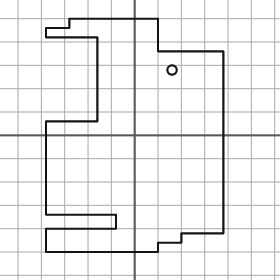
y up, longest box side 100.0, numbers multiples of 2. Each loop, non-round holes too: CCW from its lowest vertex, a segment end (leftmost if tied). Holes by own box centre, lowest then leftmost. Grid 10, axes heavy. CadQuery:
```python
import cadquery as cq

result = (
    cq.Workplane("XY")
    .moveTo(-38.0, -50.0)
    .lineTo(10.0, -50.0)
    .lineTo(10.0, -46.0)
    .lineTo(20.0, -46.0)
    .lineTo(20.0, -42.0)
    .lineTo(38.0, -42.0)
    .lineTo(38.0, 36.0)
    .lineTo(10.0, 36.0)
    .lineTo(10.0, 50.0)
    .lineTo(-28.0, 50.0)
    .lineTo(-28.0, 46.0)
    .lineTo(-38.0, 46.0)
    .lineTo(-38.0, 42.0)
    .lineTo(-16.0, 42.0)
    .lineTo(-16.0, 6.0)
    .lineTo(-38.0, 6.0)
    .lineTo(-38.0, -34.0)
    .lineTo(-8.0, -34.0)
    .lineTo(-8.0, -40.0)
    .lineTo(-38.0, -40.0)
    .close()
    .moveTo(16.0, 28.0)
    .circle(2.0)
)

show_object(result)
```